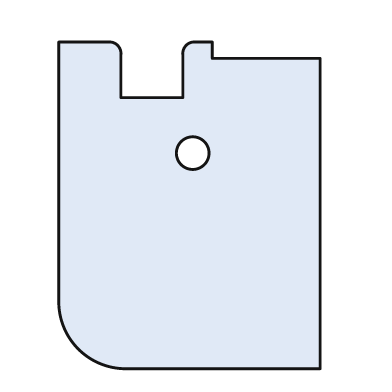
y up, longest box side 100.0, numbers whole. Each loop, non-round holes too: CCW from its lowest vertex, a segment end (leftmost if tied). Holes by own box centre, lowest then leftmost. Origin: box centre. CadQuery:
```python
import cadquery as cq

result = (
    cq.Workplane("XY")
    .moveTo(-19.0, -50.0)
    .lineTo(40.0, -50.0)
    .lineTo(40.0, 45.0)
    .lineTo(7.0, 45.0)
    .lineTo(7.0, 50.0)
    .lineTo(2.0, 50.0)
    .threePointArc((-1.0, 49.0), (-2.0, 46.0))
    .lineTo(-2.0, 33.0)
    .lineTo(-21.0, 33.0)
    .lineTo(-21.0, 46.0)
    .threePointArc((-22.0, 49.0), (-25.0, 50.0))
    .lineTo(-40.0, 50.0)
    .lineTo(-40.0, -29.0)
    .threePointArc((-34.0, -44.0), (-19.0, -50.0))
    .close()
    .moveTo(1.0, 16.0)
    .circle(5.0)
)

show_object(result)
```